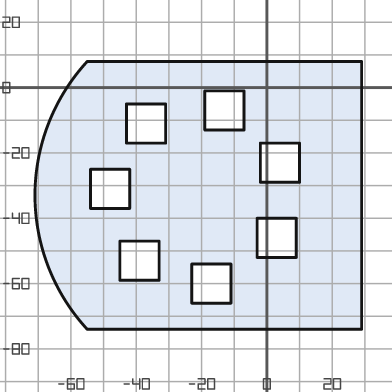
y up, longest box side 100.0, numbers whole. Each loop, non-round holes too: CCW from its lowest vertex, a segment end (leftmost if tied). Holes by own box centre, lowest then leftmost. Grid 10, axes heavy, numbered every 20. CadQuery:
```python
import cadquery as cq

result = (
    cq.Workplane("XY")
    .moveTo(-55.0, -74.0)
    .lineTo(29.0, -74.0)
    .lineTo(29.0, 8.0)
    .lineTo(-55.0, 8.0)
    .threePointArc((-71.0, -33.0), (-55.0, -74.0))
    .close()
    .moveTo(-23.0, -66.0)
    .lineTo(-11.0, -66.0)
    .lineTo(-11.0, -54.0)
    .lineTo(-23.0, -54.0)
    .close()
    .moveTo(-45.0, -59.0)
    .lineTo(-33.0, -59.0)
    .lineTo(-33.0, -47.0)
    .lineTo(-45.0, -47.0)
    .close()
    .moveTo(-3.0, -52.0)
    .lineTo(9.0, -52.0)
    .lineTo(9.0, -40.0)
    .lineTo(-3.0, -40.0)
    .close()
    .moveTo(-54.0, -37.0)
    .lineTo(-42.0, -37.0)
    .lineTo(-42.0, -25.0)
    .lineTo(-54.0, -25.0)
    .close()
    .moveTo(-2.0, -29.0)
    .lineTo(10.0, -29.0)
    .lineTo(10.0, -17.0)
    .lineTo(-2.0, -17.0)
    .close()
    .moveTo(-43.0, -17.0)
    .lineTo(-31.0, -17.0)
    .lineTo(-31.0, -5.0)
    .lineTo(-43.0, -5.0)
    .close()
    .moveTo(-19.0, -13.0)
    .lineTo(-7.0, -13.0)
    .lineTo(-7.0, -1.0)
    .lineTo(-19.0, -1.0)
    .close()
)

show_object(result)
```